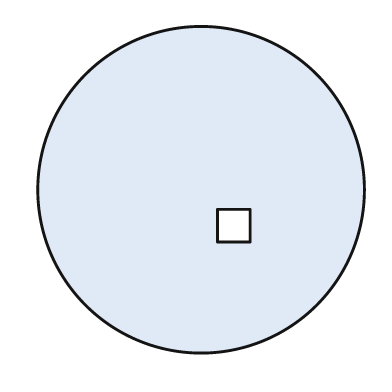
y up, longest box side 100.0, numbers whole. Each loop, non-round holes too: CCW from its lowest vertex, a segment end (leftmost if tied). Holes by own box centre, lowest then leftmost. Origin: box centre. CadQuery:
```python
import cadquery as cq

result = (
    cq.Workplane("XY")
    .moveTo(0.0, 0.0)
    .circle(50.0)
    .moveTo(5.0, -16.0)
    .lineTo(15.0, -16.0)
    .lineTo(15.0, -6.0)
    .lineTo(5.0, -6.0)
    .close()
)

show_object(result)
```